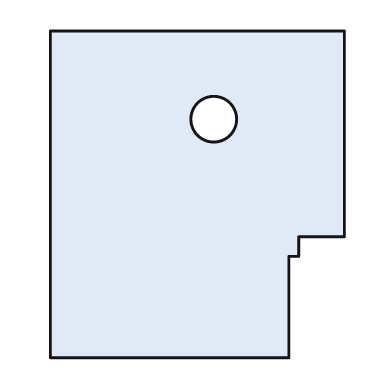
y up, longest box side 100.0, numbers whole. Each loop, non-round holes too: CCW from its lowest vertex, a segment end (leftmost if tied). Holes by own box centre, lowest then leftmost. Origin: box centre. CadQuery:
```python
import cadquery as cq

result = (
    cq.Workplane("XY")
    .moveTo(-45.0, -50.0)
    .lineTo(28.0, -50.0)
    .lineTo(28.0, -19.0)
    .lineTo(31.0, -19.0)
    .lineTo(31.0, -13.0)
    .lineTo(45.0, -13.0)
    .lineTo(45.0, 50.0)
    .lineTo(-45.0, 50.0)
    .close()
    .moveTo(5.0, 23.0)
    .circle(7.0)
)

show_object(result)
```